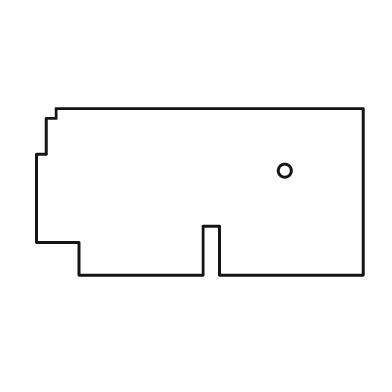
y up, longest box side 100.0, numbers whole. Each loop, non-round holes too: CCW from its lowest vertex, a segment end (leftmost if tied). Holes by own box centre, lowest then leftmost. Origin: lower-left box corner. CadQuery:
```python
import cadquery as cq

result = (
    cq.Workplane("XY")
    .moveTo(13.0, 0.0)
    .lineTo(51.0, 0.0)
    .lineTo(51.0, 15.0)
    .lineTo(56.0, 15.0)
    .lineTo(56.0, 0.0)
    .lineTo(100.0, 0.0)
    .lineTo(100.0, 51.0)
    .lineTo(6.0, 51.0)
    .lineTo(6.0, 48.0)
    .lineTo(3.0, 48.0)
    .lineTo(3.0, 37.0)
    .lineTo(0.0, 37.0)
    .lineTo(0.0, 10.0)
    .lineTo(13.0, 10.0)
    .close()
    .moveTo(76.0, 32.0)
    .circle(2.0)
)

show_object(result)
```